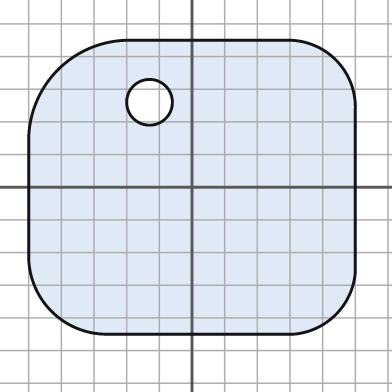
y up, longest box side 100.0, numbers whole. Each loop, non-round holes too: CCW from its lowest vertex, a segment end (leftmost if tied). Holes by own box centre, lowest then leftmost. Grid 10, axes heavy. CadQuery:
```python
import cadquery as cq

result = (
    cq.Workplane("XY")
    .moveTo(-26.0, -45.0)
    .lineTo(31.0, -45.0)
    .threePointArc((44.0, -39.0), (50.0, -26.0))
    .lineTo(50.0, 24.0)
    .threePointArc((44.0, 39.0), (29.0, 45.0))
    .lineTo(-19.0, 45.0)
    .threePointArc((-41.0, 36.0), (-50.0, 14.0))
    .lineTo(-50.0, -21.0)
    .threePointArc((-43.0, -38.0), (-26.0, -45.0))
    .close()
    .moveTo(-13.0, 26.0)
    .circle(7.0)
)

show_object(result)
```